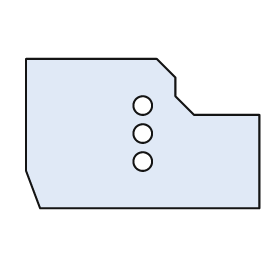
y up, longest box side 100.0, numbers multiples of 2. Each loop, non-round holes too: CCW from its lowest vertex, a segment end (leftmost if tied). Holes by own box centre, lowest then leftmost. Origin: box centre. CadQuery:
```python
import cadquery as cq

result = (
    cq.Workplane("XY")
    .moveTo(-44.0, -32.0)
    .lineTo(50.0, -32.0)
    .lineTo(50.0, 8.0)
    .lineTo(22.0, 8.0)
    .lineTo(14.0, 16.0)
    .lineTo(14.0, 24.0)
    .lineTo(6.0, 32.0)
    .lineTo(-50.0, 32.0)
    .lineTo(-50.0, -16.0)
    .close()
    .moveTo(0.0, -12.0)
    .circle(4.0)
    .moveTo(0.0, 0.0)
    .circle(4.0)
    .moveTo(0.0, 12.0)
    .circle(4.0)
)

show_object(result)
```